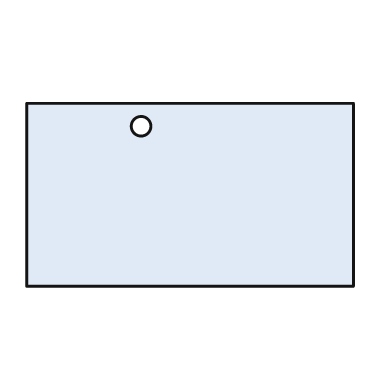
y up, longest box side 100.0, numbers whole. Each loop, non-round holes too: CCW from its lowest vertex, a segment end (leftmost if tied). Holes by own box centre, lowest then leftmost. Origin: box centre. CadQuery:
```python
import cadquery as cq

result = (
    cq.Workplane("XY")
    .moveTo(-50.0, -28.0)
    .lineTo(50.0, -28.0)
    .lineTo(50.0, 28.0)
    .lineTo(-50.0, 28.0)
    .close()
    .moveTo(-15.0, 21.0)
    .circle(3.0)
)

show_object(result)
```